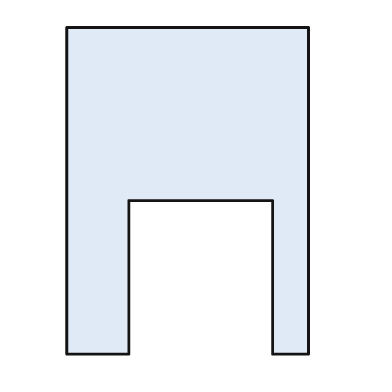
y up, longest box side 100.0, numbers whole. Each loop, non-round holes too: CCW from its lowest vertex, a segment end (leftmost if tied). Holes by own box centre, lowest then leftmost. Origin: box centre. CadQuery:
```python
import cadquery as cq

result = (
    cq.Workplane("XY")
    .moveTo(-37.0, -50.0)
    .lineTo(-18.0, -50.0)
    .lineTo(-18.0, -3.0)
    .lineTo(26.0, -3.0)
    .lineTo(26.0, -50.0)
    .lineTo(37.0, -50.0)
    .lineTo(37.0, 50.0)
    .lineTo(-37.0, 50.0)
    .close()
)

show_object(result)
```